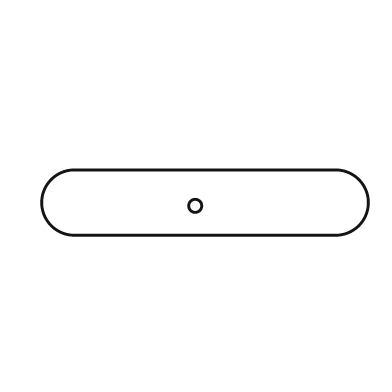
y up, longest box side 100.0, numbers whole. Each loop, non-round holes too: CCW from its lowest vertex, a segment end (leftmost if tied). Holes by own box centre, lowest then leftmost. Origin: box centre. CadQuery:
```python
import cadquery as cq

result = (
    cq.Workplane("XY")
    .moveTo(-40.0, -10.0)
    .lineTo(40.0, -10.0)
    .threePointArc((50.0, 0.0), (40.0, 10.0))
    .lineTo(-40.0, 10.0)
    .threePointArc((-50.0, 0.0), (-40.0, -10.0))
    .close()
    .moveTo(-3.0, -1.0)
    .circle(2.0)
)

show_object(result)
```